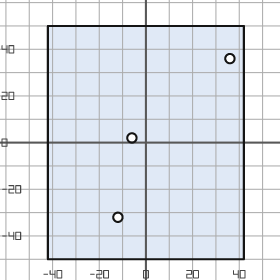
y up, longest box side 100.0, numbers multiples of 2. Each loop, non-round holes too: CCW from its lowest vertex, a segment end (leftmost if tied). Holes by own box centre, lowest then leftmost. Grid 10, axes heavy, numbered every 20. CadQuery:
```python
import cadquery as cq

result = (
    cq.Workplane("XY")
    .moveTo(-42.0, -50.0)
    .lineTo(42.0, -50.0)
    .lineTo(42.0, 50.0)
    .lineTo(-42.0, 50.0)
    .close()
    .moveTo(-12.0, -32.0)
    .circle(2.0)
    .moveTo(-6.0, 2.0)
    .circle(2.0)
    .moveTo(36.0, 36.0)
    .circle(2.0)
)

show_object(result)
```